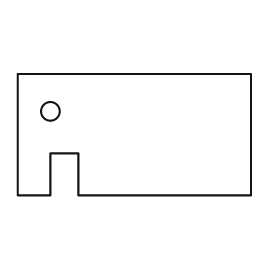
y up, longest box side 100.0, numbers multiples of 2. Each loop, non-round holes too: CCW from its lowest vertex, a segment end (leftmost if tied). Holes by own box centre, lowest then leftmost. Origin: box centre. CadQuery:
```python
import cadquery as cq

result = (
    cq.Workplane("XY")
    .moveTo(-50.0, -26.0)
    .lineTo(-36.0, -26.0)
    .lineTo(-36.0, -8.0)
    .lineTo(-24.0, -8.0)
    .lineTo(-24.0, -26.0)
    .lineTo(50.0, -26.0)
    .lineTo(50.0, 26.0)
    .lineTo(-50.0, 26.0)
    .close()
    .moveTo(-36.0, 10.0)
    .circle(4.0)
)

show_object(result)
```